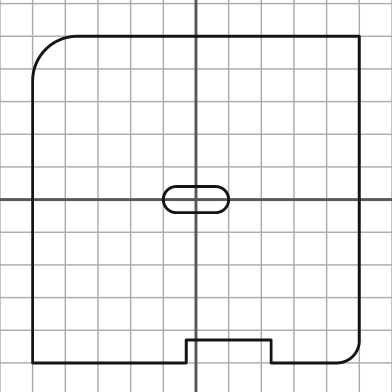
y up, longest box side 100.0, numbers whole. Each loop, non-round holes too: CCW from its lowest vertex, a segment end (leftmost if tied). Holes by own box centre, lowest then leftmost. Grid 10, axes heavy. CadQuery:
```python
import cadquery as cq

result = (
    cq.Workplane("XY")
    .moveTo(-50.0, -50.0)
    .lineTo(-3.0, -50.0)
    .lineTo(-3.0, -43.0)
    .lineTo(23.0, -43.0)
    .lineTo(23.0, -50.0)
    .lineTo(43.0, -50.0)
    .threePointArc((48.0, -48.0), (50.0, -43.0))
    .lineTo(50.0, 50.0)
    .lineTo(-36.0, 50.0)
    .threePointArc((-46.0, 46.0), (-50.0, 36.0))
    .close()
    .moveTo(-6.0, -4.0)
    .lineTo(6.0, -4.0)
    .threePointArc((10.0, 0.0), (6.0, 4.0))
    .lineTo(-6.0, 4.0)
    .threePointArc((-10.0, 0.0), (-6.0, -4.0))
    .close()
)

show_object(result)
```